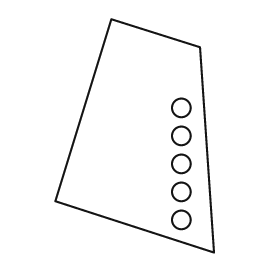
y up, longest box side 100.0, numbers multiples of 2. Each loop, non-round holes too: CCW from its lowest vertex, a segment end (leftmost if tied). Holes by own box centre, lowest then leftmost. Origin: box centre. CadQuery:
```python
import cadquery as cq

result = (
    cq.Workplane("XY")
    .moveTo(34.0, -50.0)
    .lineTo(28.0, 38.0)
    .lineTo(-10.0, 50.0)
    .lineTo(-34.0, -28.0)
    .close()
    .moveTo(20.0, -36.0)
    .circle(4.0)
    .moveTo(20.0, -24.0)
    .circle(4.0)
    .moveTo(20.0, -12.0)
    .circle(4.0)
    .moveTo(20.0, 0.0)
    .circle(4.0)
    .moveTo(20.0, 12.0)
    .circle(4.0)
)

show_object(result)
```